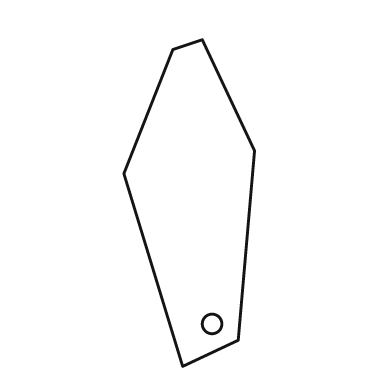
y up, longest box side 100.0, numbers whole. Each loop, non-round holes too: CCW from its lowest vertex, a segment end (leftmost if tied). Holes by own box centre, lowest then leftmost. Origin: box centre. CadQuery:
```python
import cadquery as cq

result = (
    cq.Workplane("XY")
    .moveTo(-2.0, -50.0)
    .lineTo(15.0, -42.0)
    .lineTo(20.0, 16.0)
    .lineTo(4.0, 50.0)
    .lineTo(-5.0, 47.0)
    .lineTo(-20.0, 9.0)
    .close()
    .moveTo(7.0, -37.0)
    .circle(3.0)
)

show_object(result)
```